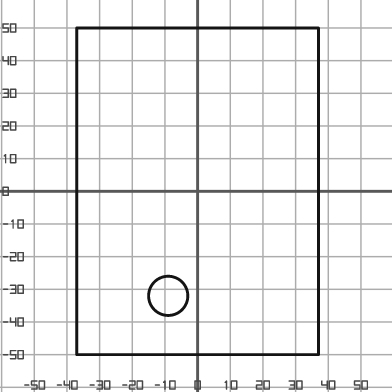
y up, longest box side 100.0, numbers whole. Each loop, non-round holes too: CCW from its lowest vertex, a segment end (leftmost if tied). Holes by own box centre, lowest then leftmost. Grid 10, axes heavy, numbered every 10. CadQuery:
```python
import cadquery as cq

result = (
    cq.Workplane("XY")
    .moveTo(-37.0, -50.0)
    .lineTo(37.0, -50.0)
    .lineTo(37.0, 50.0)
    .lineTo(-37.0, 50.0)
    .close()
    .moveTo(-9.0, -32.0)
    .circle(6.0)
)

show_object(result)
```